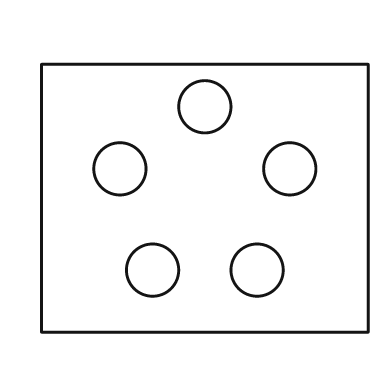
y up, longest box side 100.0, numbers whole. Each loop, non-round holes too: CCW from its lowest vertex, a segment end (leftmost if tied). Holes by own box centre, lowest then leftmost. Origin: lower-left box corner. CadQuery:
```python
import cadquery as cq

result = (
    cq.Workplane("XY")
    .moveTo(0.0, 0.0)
    .lineTo(100.0, 0.0)
    .lineTo(100.0, 82.0)
    .lineTo(0.0, 82.0)
    .close()
    .moveTo(34.0, 19.0)
    .circle(8.0)
    .moveTo(66.0, 19.0)
    .circle(8.0)
    .moveTo(24.0, 50.0)
    .circle(8.0)
    .moveTo(76.0, 50.0)
    .circle(8.0)
    .moveTo(50.0, 69.0)
    .circle(8.0)
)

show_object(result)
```